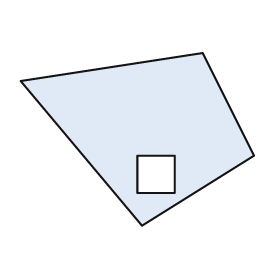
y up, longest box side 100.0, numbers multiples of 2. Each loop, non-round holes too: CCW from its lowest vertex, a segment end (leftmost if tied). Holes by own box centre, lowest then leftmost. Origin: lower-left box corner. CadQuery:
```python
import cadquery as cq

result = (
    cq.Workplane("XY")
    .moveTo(52.0, 0.0)
    .lineTo(100.0, 30.0)
    .lineTo(78.0, 74.0)
    .lineTo(0.0, 62.0)
    .close()
    .moveTo(50.0, 14.0)
    .lineTo(66.0, 14.0)
    .lineTo(66.0, 30.0)
    .lineTo(50.0, 30.0)
    .close()
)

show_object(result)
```